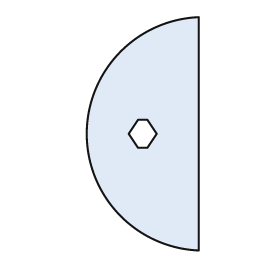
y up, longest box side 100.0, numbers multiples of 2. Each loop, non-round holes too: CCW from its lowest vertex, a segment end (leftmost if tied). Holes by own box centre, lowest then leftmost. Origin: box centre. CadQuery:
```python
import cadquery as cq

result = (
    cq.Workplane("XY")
    .moveTo(24.0, -50.0)
    .lineTo(24.0, 50.0)
    .threePointArc((-24.0, 0.0), (24.0, -50.0))
    .close()
    .moveTo(-2.0, -6.0)
    .lineTo(2.0, -6.0)
    .lineTo(6.0, 0.0)
    .lineTo(2.0, 6.0)
    .lineTo(-2.0, 6.0)
    .lineTo(-6.0, 0.0)
    .close()
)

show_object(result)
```